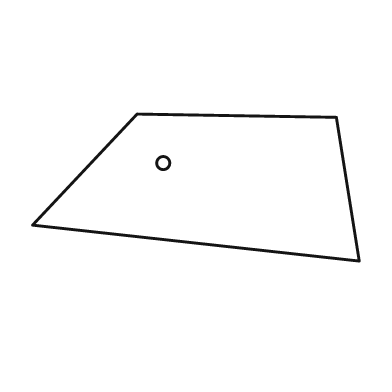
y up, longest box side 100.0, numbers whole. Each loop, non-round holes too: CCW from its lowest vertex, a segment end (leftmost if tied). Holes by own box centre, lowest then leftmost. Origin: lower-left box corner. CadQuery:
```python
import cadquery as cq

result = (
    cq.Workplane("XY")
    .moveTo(100.0, 0.0)
    .lineTo(93.0, 44.0)
    .lineTo(32.0, 45.0)
    .lineTo(0.0, 11.0)
    .close()
    .moveTo(40.0, 30.0)
    .circle(2.0)
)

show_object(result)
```